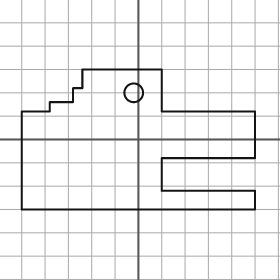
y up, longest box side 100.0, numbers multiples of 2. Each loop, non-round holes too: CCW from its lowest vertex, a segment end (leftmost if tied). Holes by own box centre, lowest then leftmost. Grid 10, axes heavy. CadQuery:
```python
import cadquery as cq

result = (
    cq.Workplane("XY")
    .moveTo(-50.0, -30.0)
    .lineTo(50.0, -30.0)
    .lineTo(50.0, -22.0)
    .lineTo(10.0, -22.0)
    .lineTo(10.0, -8.0)
    .lineTo(50.0, -8.0)
    .lineTo(50.0, 12.0)
    .lineTo(10.0, 12.0)
    .lineTo(10.0, 30.0)
    .lineTo(-24.0, 30.0)
    .lineTo(-24.0, 22.0)
    .lineTo(-28.0, 22.0)
    .lineTo(-28.0, 16.0)
    .lineTo(-38.0, 16.0)
    .lineTo(-38.0, 12.0)
    .lineTo(-50.0, 12.0)
    .close()
    .moveTo(-2.0, 20.0)
    .circle(4.0)
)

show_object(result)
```